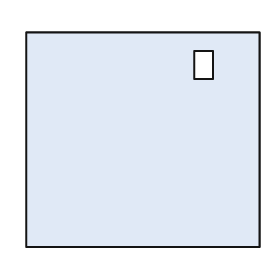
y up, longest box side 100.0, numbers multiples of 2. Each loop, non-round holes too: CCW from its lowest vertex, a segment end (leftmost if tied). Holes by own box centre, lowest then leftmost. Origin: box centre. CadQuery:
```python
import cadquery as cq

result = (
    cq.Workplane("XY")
    .moveTo(-50.0, -46.0)
    .lineTo(50.0, -46.0)
    .lineTo(50.0, 46.0)
    .lineTo(-50.0, 46.0)
    .close()
    .moveTo(22.0, 26.0)
    .lineTo(30.0, 26.0)
    .lineTo(30.0, 38.0)
    .lineTo(22.0, 38.0)
    .close()
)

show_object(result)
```